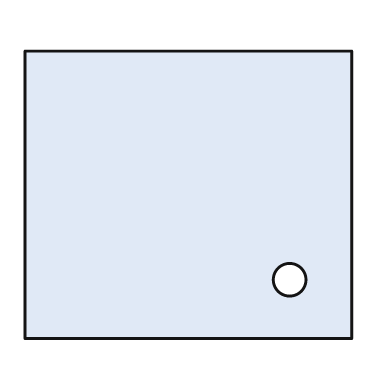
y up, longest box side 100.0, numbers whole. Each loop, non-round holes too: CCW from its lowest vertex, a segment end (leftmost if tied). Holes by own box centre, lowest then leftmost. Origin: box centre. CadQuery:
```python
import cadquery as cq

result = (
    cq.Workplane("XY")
    .moveTo(-50.0, -44.0)
    .lineTo(50.0, -44.0)
    .lineTo(50.0, 44.0)
    .lineTo(-50.0, 44.0)
    .close()
    .moveTo(31.0, -26.0)
    .circle(5.0)
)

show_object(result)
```